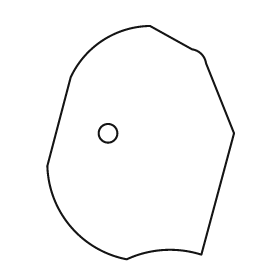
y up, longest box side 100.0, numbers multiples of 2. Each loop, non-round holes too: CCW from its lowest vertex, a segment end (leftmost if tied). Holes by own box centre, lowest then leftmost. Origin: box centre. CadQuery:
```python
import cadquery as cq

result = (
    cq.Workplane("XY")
    .moveTo(-6.0, -50.0)
    .threePointArc((10.0, -46.0), (26.0, -48.0))
    .lineTo(40.0, 4.0)
    .lineTo(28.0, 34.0)
    .threePointArc((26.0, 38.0), (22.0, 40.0))
    .lineTo(4.0, 50.0)
    .threePointArc((-16.0, 44.0), (-30.0, 28.0))
    .lineTo(-40.0, -10.0)
    .threePointArc((-30.0, -36.0), (-6.0, -50.0))
    .close()
    .moveTo(-14.0, 4.0)
    .circle(4.0)
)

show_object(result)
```